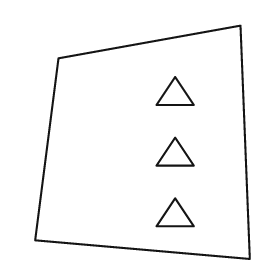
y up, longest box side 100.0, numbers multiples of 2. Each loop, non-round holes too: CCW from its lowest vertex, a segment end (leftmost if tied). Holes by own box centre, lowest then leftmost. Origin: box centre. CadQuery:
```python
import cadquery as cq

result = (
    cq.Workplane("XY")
    .moveTo(46.0, -50.0)
    .lineTo(42.0, 50.0)
    .lineTo(-36.0, 36.0)
    .lineTo(-46.0, -42.0)
    .close()
    .moveTo(6.0, -36.0)
    .lineTo(22.0, -36.0)
    .lineTo(14.0, -24.0)
    .close()
    .moveTo(6.0, -10.0)
    .lineTo(22.0, -10.0)
    .lineTo(14.0, 2.0)
    .close()
    .moveTo(6.0, 16.0)
    .lineTo(22.0, 16.0)
    .lineTo(14.0, 28.0)
    .close()
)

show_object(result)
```